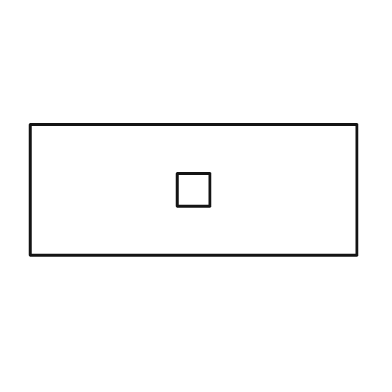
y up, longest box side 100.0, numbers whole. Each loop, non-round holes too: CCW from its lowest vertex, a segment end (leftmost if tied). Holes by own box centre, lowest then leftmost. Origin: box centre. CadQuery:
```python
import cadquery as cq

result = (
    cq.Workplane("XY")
    .moveTo(-50.0, -20.0)
    .lineTo(50.0, -20.0)
    .lineTo(50.0, 20.0)
    .lineTo(-50.0, 20.0)
    .close()
    .moveTo(-5.0, -5.0)
    .lineTo(5.0, -5.0)
    .lineTo(5.0, 5.0)
    .lineTo(-5.0, 5.0)
    .close()
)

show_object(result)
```